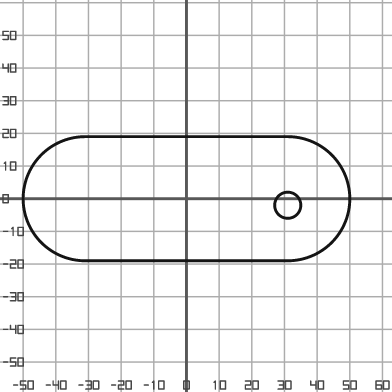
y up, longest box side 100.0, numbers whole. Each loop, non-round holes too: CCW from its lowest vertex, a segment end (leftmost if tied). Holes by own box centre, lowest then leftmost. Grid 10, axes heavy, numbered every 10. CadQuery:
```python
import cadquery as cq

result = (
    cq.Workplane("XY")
    .moveTo(-31.0, -19.0)
    .lineTo(31.0, -19.0)
    .threePointArc((50.0, 0.0), (31.0, 19.0))
    .lineTo(-31.0, 19.0)
    .threePointArc((-50.0, 0.0), (-31.0, -19.0))
    .close()
    .moveTo(31.0, -2.0)
    .circle(4.0)
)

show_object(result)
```